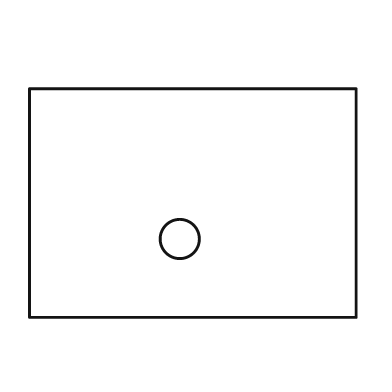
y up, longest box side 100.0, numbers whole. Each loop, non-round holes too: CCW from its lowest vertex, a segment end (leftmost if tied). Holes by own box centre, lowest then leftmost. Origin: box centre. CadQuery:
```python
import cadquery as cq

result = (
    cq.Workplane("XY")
    .moveTo(-50.0, -35.0)
    .lineTo(50.0, -35.0)
    .lineTo(50.0, 35.0)
    .lineTo(-50.0, 35.0)
    .close()
    .moveTo(-4.0, -11.0)
    .circle(6.0)
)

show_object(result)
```